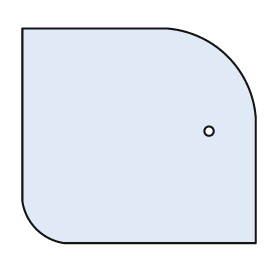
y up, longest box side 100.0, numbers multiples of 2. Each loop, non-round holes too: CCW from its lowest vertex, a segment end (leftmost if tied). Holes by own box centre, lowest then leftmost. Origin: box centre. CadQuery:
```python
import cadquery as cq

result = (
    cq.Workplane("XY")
    .moveTo(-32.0, -46.0)
    .lineTo(50.0, -46.0)
    .lineTo(50.0, 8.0)
    .threePointArc((38.0, 34.0), (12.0, 46.0))
    .lineTo(-50.0, 46.0)
    .lineTo(-50.0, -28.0)
    .threePointArc((-44.0, -40.0), (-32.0, -46.0))
    .close()
    .moveTo(30.0, 2.0)
    .circle(2.0)
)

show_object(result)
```